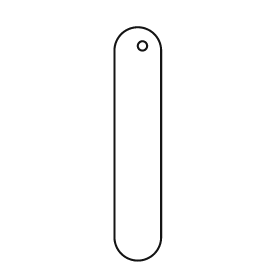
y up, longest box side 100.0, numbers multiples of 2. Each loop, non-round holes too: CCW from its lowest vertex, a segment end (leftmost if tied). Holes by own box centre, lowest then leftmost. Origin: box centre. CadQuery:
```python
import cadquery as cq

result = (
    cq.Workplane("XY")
    .moveTo(-10.0, -40.0)
    .threePointArc((0.0, -50.0), (10.0, -40.0))
    .lineTo(10.0, 40.0)
    .threePointArc((0.0, 50.0), (-10.0, 40.0))
    .close()
    .moveTo(2.0, 42.0)
    .circle(2.0)
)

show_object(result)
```